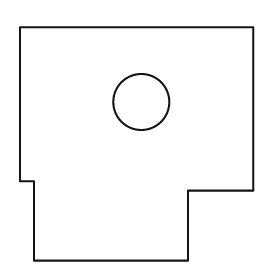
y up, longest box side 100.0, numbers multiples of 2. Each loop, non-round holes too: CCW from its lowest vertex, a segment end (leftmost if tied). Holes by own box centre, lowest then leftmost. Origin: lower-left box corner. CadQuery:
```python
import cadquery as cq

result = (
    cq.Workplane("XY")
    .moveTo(6.0, 0.0)
    .lineTo(72.0, 0.0)
    .lineTo(72.0, 30.0)
    .lineTo(100.0, 30.0)
    .lineTo(100.0, 100.0)
    .lineTo(0.0, 100.0)
    .lineTo(0.0, 34.0)
    .lineTo(6.0, 34.0)
    .close()
    .moveTo(52.0, 68.0)
    .circle(12.0)
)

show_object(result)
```